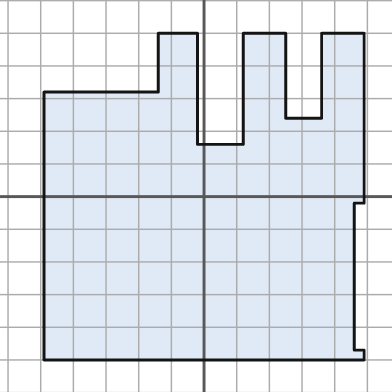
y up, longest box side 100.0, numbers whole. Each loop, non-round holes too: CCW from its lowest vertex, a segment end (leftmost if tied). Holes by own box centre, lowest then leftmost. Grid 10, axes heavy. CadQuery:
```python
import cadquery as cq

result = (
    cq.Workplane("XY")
    .moveTo(-49.0, -50.0)
    .lineTo(49.0, -50.0)
    .lineTo(49.0, -47.0)
    .lineTo(46.0, -47.0)
    .lineTo(46.0, -2.0)
    .lineTo(49.0, -2.0)
    .lineTo(49.0, 50.0)
    .lineTo(36.0, 50.0)
    .lineTo(36.0, 24.0)
    .lineTo(25.0, 24.0)
    .lineTo(25.0, 50.0)
    .lineTo(12.0, 50.0)
    .lineTo(12.0, 16.0)
    .lineTo(-2.0, 16.0)
    .lineTo(-2.0, 50.0)
    .lineTo(-14.0, 50.0)
    .lineTo(-14.0, 32.0)
    .lineTo(-49.0, 32.0)
    .close()
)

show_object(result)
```